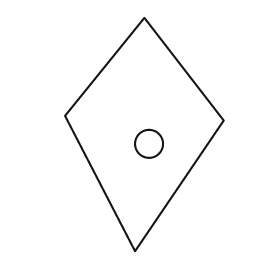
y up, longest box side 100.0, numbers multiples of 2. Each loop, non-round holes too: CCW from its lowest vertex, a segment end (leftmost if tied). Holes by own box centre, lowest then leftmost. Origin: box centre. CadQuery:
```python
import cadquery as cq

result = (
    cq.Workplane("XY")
    .moveTo(-4.0, -50.0)
    .lineTo(34.0, 6.0)
    .lineTo(0.0, 50.0)
    .lineTo(-34.0, 8.0)
    .close()
    .moveTo(2.0, -4.0)
    .circle(6.0)
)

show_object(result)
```